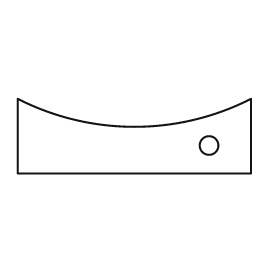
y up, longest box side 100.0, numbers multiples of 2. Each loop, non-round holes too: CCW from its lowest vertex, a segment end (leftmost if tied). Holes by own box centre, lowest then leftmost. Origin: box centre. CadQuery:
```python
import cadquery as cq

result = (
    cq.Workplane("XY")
    .moveTo(-50.0, -16.0)
    .lineTo(50.0, -16.0)
    .lineTo(50.0, 16.0)
    .threePointArc((0.0, 4.0), (-50.0, 16.0))
    .close()
    .moveTo(32.0, -4.0)
    .circle(4.0)
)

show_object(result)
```